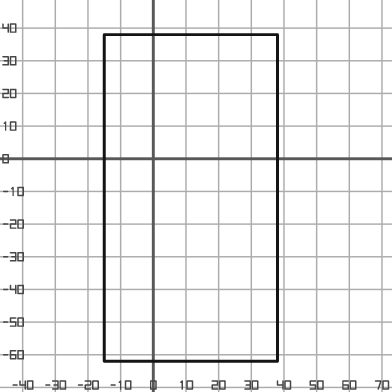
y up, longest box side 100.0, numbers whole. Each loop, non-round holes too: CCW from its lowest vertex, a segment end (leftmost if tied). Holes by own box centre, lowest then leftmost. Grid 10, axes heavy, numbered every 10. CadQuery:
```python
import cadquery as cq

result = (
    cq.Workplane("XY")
    .moveTo(-15.0, -62.0)
    .lineTo(38.0, -62.0)
    .lineTo(38.0, 38.0)
    .lineTo(-15.0, 38.0)
    .close()
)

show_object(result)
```